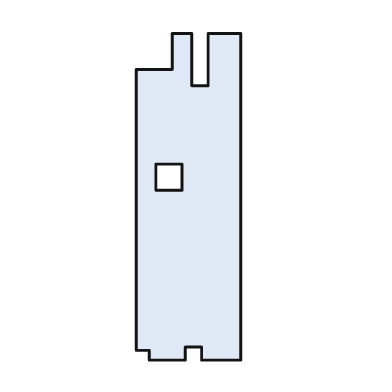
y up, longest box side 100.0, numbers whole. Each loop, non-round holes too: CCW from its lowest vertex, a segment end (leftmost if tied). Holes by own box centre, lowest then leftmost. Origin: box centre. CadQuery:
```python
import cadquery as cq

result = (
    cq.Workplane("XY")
    .moveTo(-12.0, -50.0)
    .lineTo(-1.0, -50.0)
    .lineTo(-1.0, -46.0)
    .lineTo(4.0, -46.0)
    .lineTo(4.0, -50.0)
    .lineTo(16.0, -50.0)
    .lineTo(16.0, 50.0)
    .lineTo(6.0, 50.0)
    .lineTo(6.0, 34.0)
    .lineTo(1.0, 34.0)
    .lineTo(1.0, 50.0)
    .lineTo(-5.0, 50.0)
    .lineTo(-5.0, 39.0)
    .lineTo(-16.0, 39.0)
    .lineTo(-16.0, -47.0)
    .lineTo(-12.0, -47.0)
    .close()
    .moveTo(-10.0, 2.0)
    .lineTo(-2.0, 2.0)
    .lineTo(-2.0, 10.0)
    .lineTo(-10.0, 10.0)
    .close()
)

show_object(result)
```